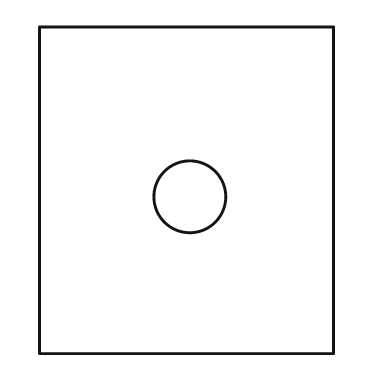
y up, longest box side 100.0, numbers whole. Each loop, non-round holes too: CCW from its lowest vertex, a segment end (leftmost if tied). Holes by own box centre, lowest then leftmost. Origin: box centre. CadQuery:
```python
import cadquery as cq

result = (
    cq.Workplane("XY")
    .moveTo(-45.0, -50.0)
    .lineTo(45.0, -50.0)
    .lineTo(45.0, 50.0)
    .lineTo(-45.0, 50.0)
    .close()
    .moveTo(1.0, -2.0)
    .circle(11.0)
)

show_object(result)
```